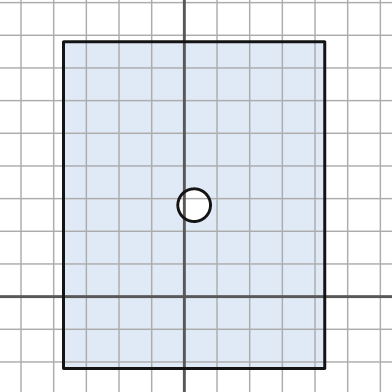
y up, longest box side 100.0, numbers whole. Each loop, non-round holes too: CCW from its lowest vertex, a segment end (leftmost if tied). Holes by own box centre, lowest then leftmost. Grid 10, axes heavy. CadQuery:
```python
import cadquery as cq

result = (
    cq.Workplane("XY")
    .moveTo(-37.0, -22.0)
    .lineTo(43.0, -22.0)
    .lineTo(43.0, 78.0)
    .lineTo(-37.0, 78.0)
    .close()
    .moveTo(3.0, 28.0)
    .circle(5.0)
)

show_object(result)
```